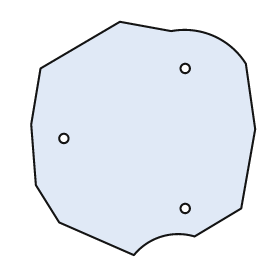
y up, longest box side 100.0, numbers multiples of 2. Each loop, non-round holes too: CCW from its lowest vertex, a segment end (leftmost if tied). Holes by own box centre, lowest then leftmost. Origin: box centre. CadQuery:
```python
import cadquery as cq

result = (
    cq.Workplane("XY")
    .moveTo(-4.0, -50.0)
    .threePointArc((8.0, -42.0), (22.0, -42.0))
    .lineTo(42.0, -30.0)
    .lineTo(48.0, 4.0)
    .lineTo(44.0, 32.0)
    .threePointArc((30.0, 44.0), (12.0, 46.0))
    .lineTo(-10.0, 50.0)
    .lineTo(-44.0, 30.0)
    .lineTo(-48.0, 6.0)
    .lineTo(-46.0, -20.0)
    .lineTo(-36.0, -36.0)
    .close()
    .moveTo(18.0, -30.0)
    .circle(2.0)
    .moveTo(-34.0, 0.0)
    .circle(2.0)
    .moveTo(18.0, 30.0)
    .circle(2.0)
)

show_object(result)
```